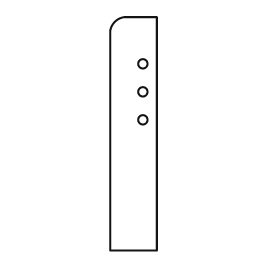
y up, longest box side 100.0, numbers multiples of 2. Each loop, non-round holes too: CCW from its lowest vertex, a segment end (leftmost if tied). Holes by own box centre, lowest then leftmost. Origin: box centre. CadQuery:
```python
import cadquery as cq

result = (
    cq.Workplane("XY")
    .moveTo(-10.0, -50.0)
    .lineTo(10.0, -50.0)
    .lineTo(10.0, 50.0)
    .lineTo(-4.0, 50.0)
    .threePointArc((-8.0, 48.0), (-10.0, 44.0))
    .close()
    .moveTo(4.0, 6.0)
    .circle(2.0)
    .moveTo(4.0, 18.0)
    .circle(2.0)
    .moveTo(4.0, 30.0)
    .circle(2.0)
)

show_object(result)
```